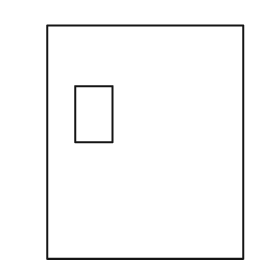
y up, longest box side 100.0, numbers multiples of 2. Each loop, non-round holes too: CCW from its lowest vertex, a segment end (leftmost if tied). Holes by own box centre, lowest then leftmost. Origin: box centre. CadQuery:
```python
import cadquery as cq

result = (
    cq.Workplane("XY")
    .moveTo(-42.0, -50.0)
    .lineTo(42.0, -50.0)
    .lineTo(42.0, 50.0)
    .lineTo(-42.0, 50.0)
    .close()
    .moveTo(-30.0, 0.0)
    .lineTo(-14.0, 0.0)
    .lineTo(-14.0, 24.0)
    .lineTo(-30.0, 24.0)
    .close()
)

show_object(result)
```